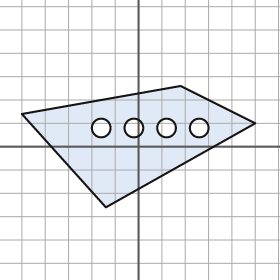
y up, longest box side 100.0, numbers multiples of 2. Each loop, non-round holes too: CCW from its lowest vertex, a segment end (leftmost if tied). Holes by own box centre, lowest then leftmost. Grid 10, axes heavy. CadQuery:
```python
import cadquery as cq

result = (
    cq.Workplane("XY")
    .moveTo(-14.0, -26.0)
    .lineTo(50.0, 10.0)
    .lineTo(18.0, 26.0)
    .lineTo(-50.0, 14.0)
    .close()
    .moveTo(-16.0, 8.0)
    .circle(4.0)
    .moveTo(-2.0, 8.0)
    .circle(4.0)
    .moveTo(12.0, 8.0)
    .circle(4.0)
    .moveTo(26.0, 8.0)
    .circle(4.0)
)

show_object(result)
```